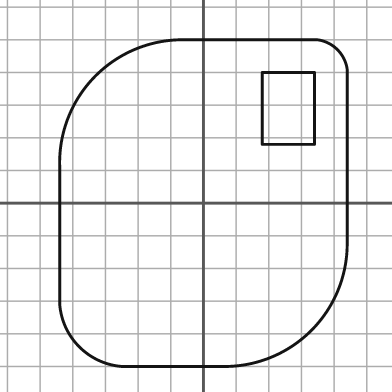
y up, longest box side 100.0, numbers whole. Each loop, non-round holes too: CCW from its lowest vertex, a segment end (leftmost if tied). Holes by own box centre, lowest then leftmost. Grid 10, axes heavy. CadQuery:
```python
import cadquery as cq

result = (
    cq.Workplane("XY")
    .moveTo(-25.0, -50.0)
    .lineTo(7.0, -50.0)
    .threePointArc((33.0, -39.0), (44.0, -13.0))
    .lineTo(44.0, 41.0)
    .threePointArc((41.0, 47.0), (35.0, 50.0))
    .lineTo(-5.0, 50.0)
    .threePointArc((-33.0, 39.0), (-44.0, 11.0))
    .lineTo(-44.0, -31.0)
    .threePointArc((-38.0, -44.0), (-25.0, -50.0))
    .close()
    .moveTo(18.0, 18.0)
    .lineTo(34.0, 18.0)
    .lineTo(34.0, 40.0)
    .lineTo(18.0, 40.0)
    .close()
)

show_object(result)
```